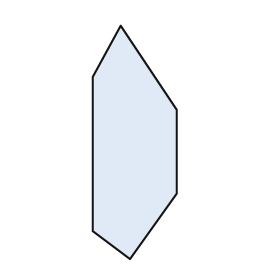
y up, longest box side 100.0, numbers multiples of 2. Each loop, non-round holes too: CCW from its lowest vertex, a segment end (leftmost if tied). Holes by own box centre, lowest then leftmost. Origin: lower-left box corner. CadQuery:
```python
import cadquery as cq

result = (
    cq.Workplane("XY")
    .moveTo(16.0, 0.0)
    .lineTo(36.0, 28.0)
    .lineTo(36.0, 64.0)
    .lineTo(12.0, 100.0)
    .lineTo(0.0, 78.0)
    .lineTo(0.0, 12.0)
    .close()
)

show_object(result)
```